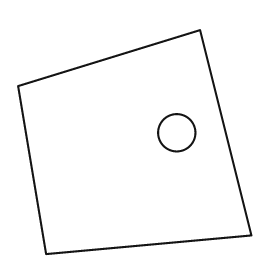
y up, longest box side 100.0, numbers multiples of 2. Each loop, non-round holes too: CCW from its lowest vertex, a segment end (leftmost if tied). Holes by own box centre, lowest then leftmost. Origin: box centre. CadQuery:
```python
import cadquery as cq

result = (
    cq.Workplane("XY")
    .moveTo(-38.0, -48.0)
    .lineTo(50.0, -40.0)
    .lineTo(28.0, 48.0)
    .lineTo(-50.0, 24.0)
    .close()
    .moveTo(18.0, 4.0)
    .circle(8.0)
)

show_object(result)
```